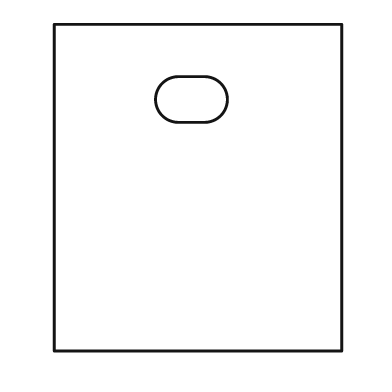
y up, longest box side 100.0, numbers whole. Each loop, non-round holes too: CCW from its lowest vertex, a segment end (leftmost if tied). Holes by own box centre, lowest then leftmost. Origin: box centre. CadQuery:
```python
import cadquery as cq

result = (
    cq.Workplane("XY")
    .moveTo(-44.0, -50.0)
    .lineTo(44.0, -50.0)
    .lineTo(44.0, 50.0)
    .lineTo(-44.0, 50.0)
    .close()
    .moveTo(-6.0, 20.0)
    .lineTo(2.0, 20.0)
    .threePointArc((9.0, 27.0), (2.0, 34.0))
    .lineTo(-6.0, 34.0)
    .threePointArc((-13.0, 27.0), (-6.0, 20.0))
    .close()
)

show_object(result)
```